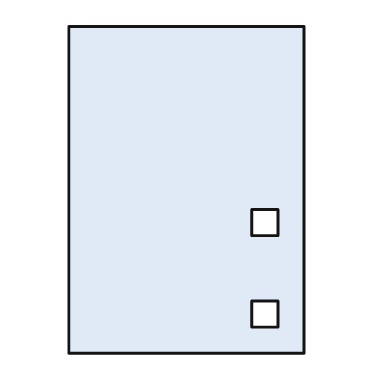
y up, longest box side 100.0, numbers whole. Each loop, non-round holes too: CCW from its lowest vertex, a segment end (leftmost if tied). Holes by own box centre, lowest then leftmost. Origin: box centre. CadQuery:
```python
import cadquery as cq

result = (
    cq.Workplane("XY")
    .moveTo(-36.0, -50.0)
    .lineTo(36.0, -50.0)
    .lineTo(36.0, 50.0)
    .lineTo(-36.0, 50.0)
    .close()
    .moveTo(20.0, -42.0)
    .lineTo(28.0, -42.0)
    .lineTo(28.0, -34.0)
    .lineTo(20.0, -34.0)
    .close()
    .moveTo(20.0, -14.0)
    .lineTo(28.0, -14.0)
    .lineTo(28.0, -6.0)
    .lineTo(20.0, -6.0)
    .close()
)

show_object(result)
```